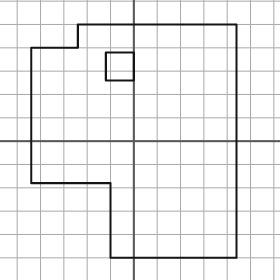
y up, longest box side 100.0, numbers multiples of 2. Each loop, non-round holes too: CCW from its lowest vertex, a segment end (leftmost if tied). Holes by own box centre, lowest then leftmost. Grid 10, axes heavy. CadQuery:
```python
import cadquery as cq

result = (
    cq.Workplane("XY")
    .moveTo(-10.0, -50.0)
    .lineTo(44.0, -50.0)
    .lineTo(44.0, 50.0)
    .lineTo(-24.0, 50.0)
    .lineTo(-24.0, 40.0)
    .lineTo(-44.0, 40.0)
    .lineTo(-44.0, -18.0)
    .lineTo(-10.0, -18.0)
    .close()
    .moveTo(-12.0, 26.0)
    .lineTo(0.0, 26.0)
    .lineTo(0.0, 38.0)
    .lineTo(-12.0, 38.0)
    .close()
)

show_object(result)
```